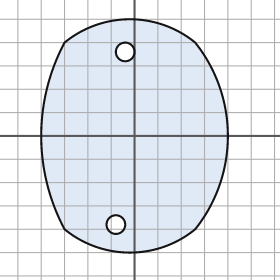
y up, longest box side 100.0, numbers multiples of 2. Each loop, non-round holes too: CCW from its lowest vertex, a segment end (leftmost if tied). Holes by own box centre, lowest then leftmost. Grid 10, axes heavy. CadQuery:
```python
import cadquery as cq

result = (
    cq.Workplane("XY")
    .moveTo(-30.0, -40.0)
    .threePointArc((-2.0, -50.0), (26.0, -40.0))
    .threePointArc((40.0, 0.0), (26.0, 40.0))
    .threePointArc((-2.0, 50.0), (-30.0, 40.0))
    .threePointArc((-40.0, 0.0), (-30.0, -40.0))
    .close()
    .moveTo(-8.0, -38.0)
    .circle(4.0)
    .moveTo(-4.0, 36.0)
    .circle(4.0)
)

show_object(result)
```